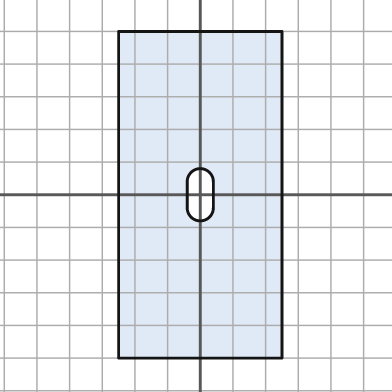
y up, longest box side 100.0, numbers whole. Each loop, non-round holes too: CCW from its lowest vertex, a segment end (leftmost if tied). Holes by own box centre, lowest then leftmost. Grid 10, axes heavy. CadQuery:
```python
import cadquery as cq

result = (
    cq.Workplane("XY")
    .moveTo(-25.0, -50.0)
    .lineTo(25.0, -50.0)
    .lineTo(25.0, 50.0)
    .lineTo(-25.0, 50.0)
    .close()
    .moveTo(-4.0, -4.0)
    .threePointArc((0.0, -8.0), (4.0, -4.0))
    .lineTo(4.0, 4.0)
    .threePointArc((0.0, 8.0), (-4.0, 4.0))
    .close()
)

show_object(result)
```